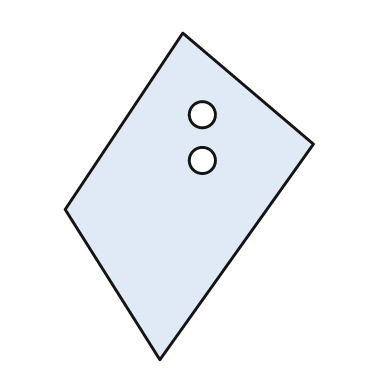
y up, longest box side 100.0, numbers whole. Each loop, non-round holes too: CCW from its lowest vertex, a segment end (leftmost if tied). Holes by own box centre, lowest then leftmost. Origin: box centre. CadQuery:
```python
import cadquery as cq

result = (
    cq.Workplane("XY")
    .moveTo(-9.0, -50.0)
    .lineTo(38.0, 16.0)
    .lineTo(-2.0, 50.0)
    .lineTo(-38.0, -4.0)
    .close()
    .moveTo(4.0, 11.0)
    .circle(4.0)
    .moveTo(4.0, 25.0)
    .circle(4.0)
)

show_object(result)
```